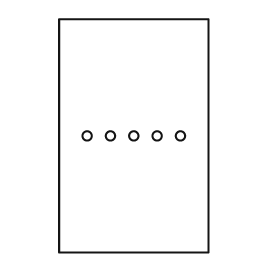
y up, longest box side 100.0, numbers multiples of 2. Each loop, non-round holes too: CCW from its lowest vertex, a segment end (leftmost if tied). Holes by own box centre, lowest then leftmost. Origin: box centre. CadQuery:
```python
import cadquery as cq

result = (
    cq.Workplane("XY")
    .moveTo(-32.0, -50.0)
    .lineTo(32.0, -50.0)
    .lineTo(32.0, 50.0)
    .lineTo(-32.0, 50.0)
    .close()
    .moveTo(-20.0, 0.0)
    .circle(2.0)
    .moveTo(-10.0, 0.0)
    .circle(2.0)
    .moveTo(0.0, 0.0)
    .circle(2.0)
    .moveTo(10.0, 0.0)
    .circle(2.0)
    .moveTo(20.0, 0.0)
    .circle(2.0)
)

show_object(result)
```